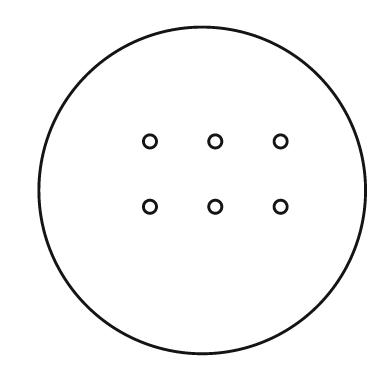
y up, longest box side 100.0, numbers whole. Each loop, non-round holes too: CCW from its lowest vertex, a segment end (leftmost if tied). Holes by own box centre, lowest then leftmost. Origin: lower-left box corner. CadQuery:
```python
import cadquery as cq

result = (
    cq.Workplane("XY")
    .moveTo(50.0, 50.0)
    .circle(50.0)
    .moveTo(34.0, 45.0)
    .circle(2.0)
    .moveTo(54.0, 45.0)
    .circle(2.0)
    .moveTo(74.0, 45.0)
    .circle(2.0)
    .moveTo(34.0, 65.0)
    .circle(2.0)
    .moveTo(54.0, 65.0)
    .circle(2.0)
    .moveTo(74.0, 65.0)
    .circle(2.0)
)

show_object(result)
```